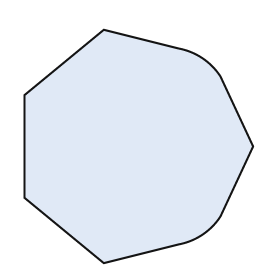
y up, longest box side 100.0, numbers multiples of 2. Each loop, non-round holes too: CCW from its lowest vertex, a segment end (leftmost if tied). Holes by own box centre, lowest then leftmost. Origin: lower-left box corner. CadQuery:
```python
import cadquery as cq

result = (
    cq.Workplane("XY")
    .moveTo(34.0, 0.0)
    .lineTo(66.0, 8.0)
    .threePointArc((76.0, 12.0), (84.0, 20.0))
    .lineTo(98.0, 50.0)
    .lineTo(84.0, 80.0)
    .threePointArc((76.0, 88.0), (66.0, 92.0))
    .lineTo(34.0, 100.0)
    .lineTo(0.0, 72.0)
    .lineTo(0.0, 28.0)
    .close()
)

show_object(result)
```